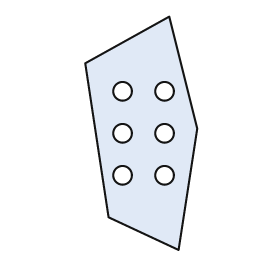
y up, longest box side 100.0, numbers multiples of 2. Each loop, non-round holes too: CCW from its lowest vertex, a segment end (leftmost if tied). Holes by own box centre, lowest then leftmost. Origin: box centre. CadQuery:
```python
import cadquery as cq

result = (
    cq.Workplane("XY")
    .moveTo(16.0, -50.0)
    .lineTo(24.0, 2.0)
    .lineTo(12.0, 50.0)
    .lineTo(-24.0, 30.0)
    .lineTo(-14.0, -36.0)
    .close()
    .moveTo(-8.0, -18.0)
    .circle(4.0)
    .moveTo(10.0, -18.0)
    .circle(4.0)
    .moveTo(-8.0, 0.0)
    .circle(4.0)
    .moveTo(10.0, 0.0)
    .circle(4.0)
    .moveTo(-8.0, 18.0)
    .circle(4.0)
    .moveTo(10.0, 18.0)
    .circle(4.0)
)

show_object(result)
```